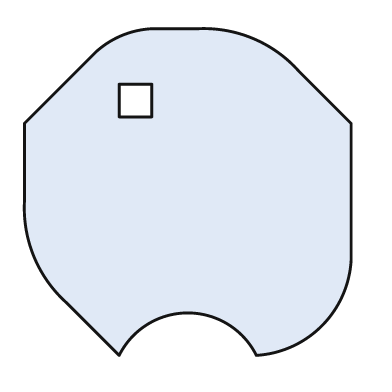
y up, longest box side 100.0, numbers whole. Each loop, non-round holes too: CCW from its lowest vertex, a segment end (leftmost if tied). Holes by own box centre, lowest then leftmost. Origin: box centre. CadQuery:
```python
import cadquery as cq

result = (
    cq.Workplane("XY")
    .moveTo(-21.0, -50.0)
    .threePointArc((0.0, -37.0), (21.0, -50.0))
    .threePointArc((41.0, -41.0), (50.0, -21.0))
    .lineTo(50.0, 21.0)
    .lineTo(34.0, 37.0)
    .threePointArc((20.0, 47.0), (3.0, 50.0))
    .lineTo(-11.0, 50.0)
    .threePointArc((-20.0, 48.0), (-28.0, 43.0))
    .lineTo(-50.0, 21.0)
    .lineTo(-50.0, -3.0)
    .threePointArc((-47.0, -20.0), (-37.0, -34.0))
    .close()
    .moveTo(-21.0, 23.0)
    .lineTo(-11.0, 23.0)
    .lineTo(-11.0, 33.0)
    .lineTo(-21.0, 33.0)
    .close()
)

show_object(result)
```